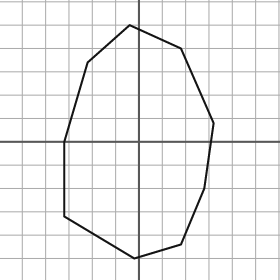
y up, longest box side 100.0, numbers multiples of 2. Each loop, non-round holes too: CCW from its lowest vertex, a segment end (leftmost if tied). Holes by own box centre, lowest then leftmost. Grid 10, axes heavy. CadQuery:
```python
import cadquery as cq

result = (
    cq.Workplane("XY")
    .moveTo(-2.0, -50.0)
    .lineTo(18.0, -44.0)
    .lineTo(28.0, -20.0)
    .lineTo(32.0, 8.0)
    .lineTo(18.0, 40.0)
    .lineTo(-4.0, 50.0)
    .lineTo(-22.0, 34.0)
    .lineTo(-32.0, 0.0)
    .lineTo(-32.0, -32.0)
    .close()
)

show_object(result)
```